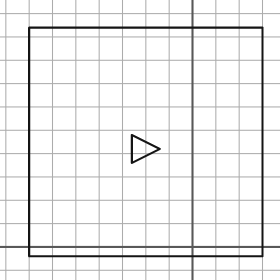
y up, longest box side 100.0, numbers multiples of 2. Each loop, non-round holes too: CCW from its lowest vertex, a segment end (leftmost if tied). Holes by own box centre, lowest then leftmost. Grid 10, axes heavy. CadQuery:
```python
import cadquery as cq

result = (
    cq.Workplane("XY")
    .moveTo(-70.0, -4.0)
    .lineTo(30.0, -4.0)
    .lineTo(30.0, 94.0)
    .lineTo(-70.0, 94.0)
    .close()
    .moveTo(-26.0, 36.0)
    .lineTo(-14.0, 42.0)
    .lineTo(-26.0, 48.0)
    .close()
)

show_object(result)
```